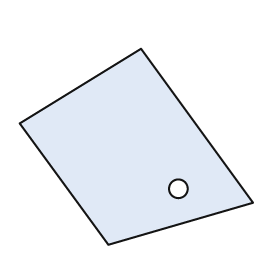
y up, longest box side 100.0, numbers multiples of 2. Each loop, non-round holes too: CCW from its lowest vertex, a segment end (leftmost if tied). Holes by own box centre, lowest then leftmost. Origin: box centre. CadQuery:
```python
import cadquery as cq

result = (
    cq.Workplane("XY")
    .moveTo(-12.0, -42.0)
    .lineTo(50.0, -24.0)
    .lineTo(2.0, 42.0)
    .lineTo(-50.0, 10.0)
    .close()
    .moveTo(18.0, -18.0)
    .circle(4.0)
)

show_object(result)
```